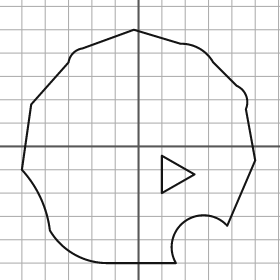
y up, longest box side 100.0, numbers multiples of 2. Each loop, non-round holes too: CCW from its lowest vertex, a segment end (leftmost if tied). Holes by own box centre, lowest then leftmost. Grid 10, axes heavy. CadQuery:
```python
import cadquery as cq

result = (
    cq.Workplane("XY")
    .moveTo(-14.0, -50.0)
    .lineTo(16.0, -50.0)
    .threePointArc((20.0, -32.0), (38.0, -34.0))
    .lineTo(50.0, -6.0)
    .lineTo(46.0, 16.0)
    .threePointArc((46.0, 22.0), (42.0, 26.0))
    .lineTo(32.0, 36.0)
    .threePointArc((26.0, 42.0), (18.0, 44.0))
    .lineTo(-2.0, 50.0)
    .lineTo(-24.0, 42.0)
    .threePointArc((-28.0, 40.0), (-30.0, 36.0))
    .lineTo(-46.0, 18.0)
    .lineTo(-50.0, -10.0)
    .threePointArc((-42.0, -22.0), (-38.0, -36.0))
    .threePointArc((-28.0, -46.0), (-14.0, -50.0))
    .close()
    .moveTo(10.0, -20.0)
    .lineTo(24.0, -12.0)
    .lineTo(10.0, -4.0)
    .close()
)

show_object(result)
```